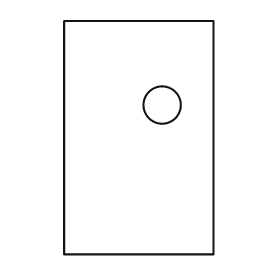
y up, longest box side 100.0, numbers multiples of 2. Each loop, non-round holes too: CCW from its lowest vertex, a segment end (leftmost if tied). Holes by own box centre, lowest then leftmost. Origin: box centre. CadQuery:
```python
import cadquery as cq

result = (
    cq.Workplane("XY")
    .moveTo(-32.0, -50.0)
    .lineTo(32.0, -50.0)
    .lineTo(32.0, 50.0)
    .lineTo(-32.0, 50.0)
    .close()
    .moveTo(10.0, 14.0)
    .circle(8.0)
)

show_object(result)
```